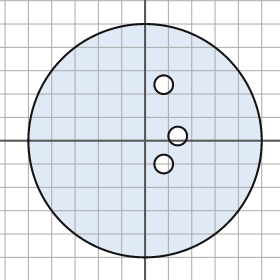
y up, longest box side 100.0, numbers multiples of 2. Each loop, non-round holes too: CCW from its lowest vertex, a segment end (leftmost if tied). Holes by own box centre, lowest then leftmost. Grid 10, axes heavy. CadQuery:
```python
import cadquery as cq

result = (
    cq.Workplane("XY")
    .moveTo(0.0, 0.0)
    .circle(50.0)
    .moveTo(8.0, -10.0)
    .circle(4.0)
    .moveTo(14.0, 2.0)
    .circle(4.0)
    .moveTo(8.0, 24.0)
    .circle(4.0)
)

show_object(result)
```